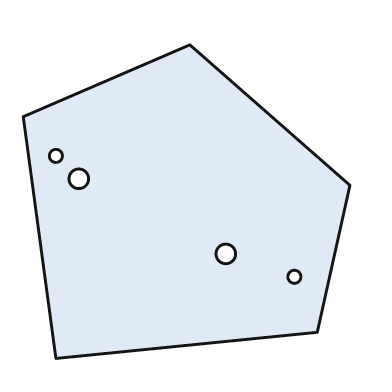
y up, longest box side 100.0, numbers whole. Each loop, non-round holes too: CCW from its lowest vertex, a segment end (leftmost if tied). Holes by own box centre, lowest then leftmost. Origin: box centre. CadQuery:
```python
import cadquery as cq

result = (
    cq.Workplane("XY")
    .moveTo(-40.0, -48.0)
    .lineTo(40.0, -40.0)
    .lineTo(50.0, 5.0)
    .lineTo(1.0, 48.0)
    .lineTo(-50.0, 26.0)
    .close()
    .moveTo(33.0, -23.0)
    .circle(2.0)
    .moveTo(12.0, -16.0)
    .circle(3.0)
    .moveTo(-33.0, 7.0)
    .circle(3.0)
    .moveTo(-40.0, 14.0)
    .circle(2.0)
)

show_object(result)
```